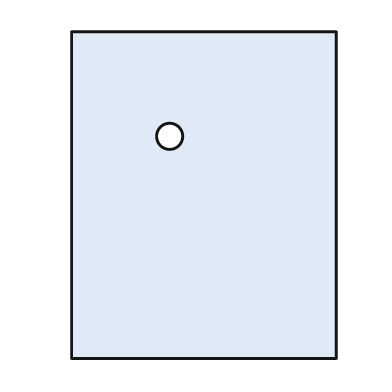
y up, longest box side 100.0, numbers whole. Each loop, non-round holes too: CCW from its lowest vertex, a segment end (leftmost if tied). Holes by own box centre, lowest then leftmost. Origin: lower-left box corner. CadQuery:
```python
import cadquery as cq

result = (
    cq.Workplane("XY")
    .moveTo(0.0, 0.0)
    .lineTo(81.0, 0.0)
    .lineTo(81.0, 100.0)
    .lineTo(0.0, 100.0)
    .close()
    .moveTo(30.0, 68.0)
    .circle(4.0)
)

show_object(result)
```